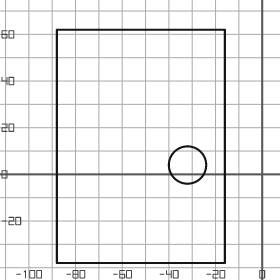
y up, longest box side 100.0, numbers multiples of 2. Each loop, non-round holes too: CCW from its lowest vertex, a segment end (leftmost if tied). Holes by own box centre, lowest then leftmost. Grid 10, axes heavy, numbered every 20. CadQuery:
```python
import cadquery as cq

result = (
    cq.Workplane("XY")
    .moveTo(-88.0, -38.0)
    .lineTo(-16.0, -38.0)
    .lineTo(-16.0, 62.0)
    .lineTo(-88.0, 62.0)
    .close()
    .moveTo(-32.0, 4.0)
    .circle(8.0)
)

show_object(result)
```